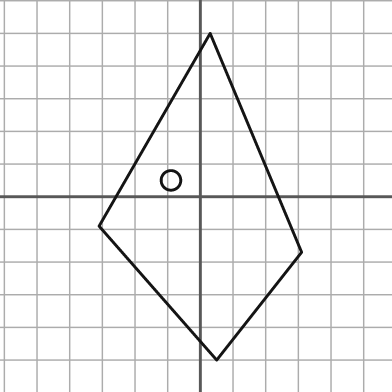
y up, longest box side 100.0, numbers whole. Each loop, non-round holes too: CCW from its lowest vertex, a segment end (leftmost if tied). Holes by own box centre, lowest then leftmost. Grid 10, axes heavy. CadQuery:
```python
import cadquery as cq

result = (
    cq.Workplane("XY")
    .moveTo(5.0, -50.0)
    .lineTo(31.0, -17.0)
    .lineTo(3.0, 50.0)
    .lineTo(-31.0, -9.0)
    .close()
    .moveTo(-9.0, 5.0)
    .circle(3.0)
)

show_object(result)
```